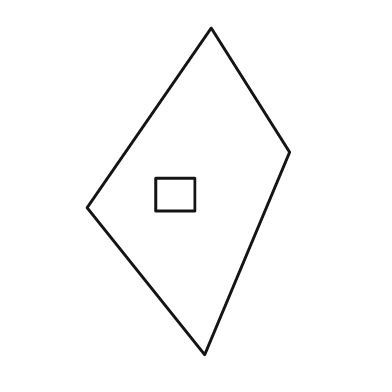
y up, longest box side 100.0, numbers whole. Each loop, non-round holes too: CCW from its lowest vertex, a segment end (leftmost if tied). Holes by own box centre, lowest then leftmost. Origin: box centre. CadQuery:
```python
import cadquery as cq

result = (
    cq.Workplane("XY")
    .moveTo(5.0, -50.0)
    .lineTo(31.0, 12.0)
    .lineTo(7.0, 50.0)
    .lineTo(-31.0, -5.0)
    .close()
    .moveTo(-10.0, -6.0)
    .lineTo(2.0, -6.0)
    .lineTo(2.0, 4.0)
    .lineTo(-10.0, 4.0)
    .close()
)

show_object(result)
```